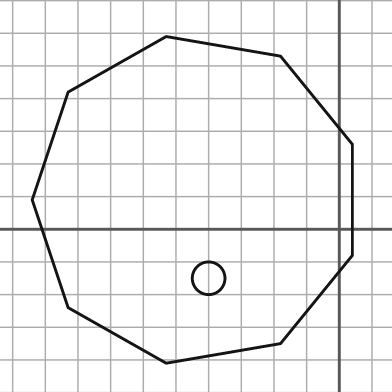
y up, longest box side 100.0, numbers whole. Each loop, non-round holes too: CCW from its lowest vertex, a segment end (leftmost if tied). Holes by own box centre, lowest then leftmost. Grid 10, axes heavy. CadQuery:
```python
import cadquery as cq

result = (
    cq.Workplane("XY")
    .moveTo(-53.0, -41.0)
    .lineTo(-18.0, -35.0)
    .lineTo(4.0, -8.0)
    .lineTo(4.0, 26.0)
    .lineTo(-18.0, 53.0)
    .lineTo(-53.0, 59.0)
    .lineTo(-83.0, 42.0)
    .lineTo(-94.0, 9.0)
    .lineTo(-83.0, -24.0)
    .close()
    .moveTo(-40.0, -15.0)
    .circle(5.0)
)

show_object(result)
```